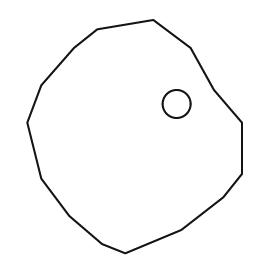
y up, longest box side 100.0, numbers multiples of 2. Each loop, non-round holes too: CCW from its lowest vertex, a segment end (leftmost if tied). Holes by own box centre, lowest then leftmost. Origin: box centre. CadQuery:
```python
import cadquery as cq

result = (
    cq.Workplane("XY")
    .moveTo(-4.0, -50.0)
    .lineTo(20.0, -40.0)
    .lineTo(38.0, -26.0)
    .lineTo(46.0, -16.0)
    .lineTo(46.0, 6.0)
    .lineTo(34.0, 20.0)
    .lineTo(24.0, 38.0)
    .lineTo(8.0, 50.0)
    .lineTo(-16.0, 46.0)
    .lineTo(-26.0, 38.0)
    .lineTo(-40.0, 22.0)
    .lineTo(-46.0, 6.0)
    .lineTo(-40.0, -18.0)
    .lineTo(-28.0, -34.0)
    .lineTo(-14.0, -46.0)
    .close()
    .moveTo(18.0, 14.0)
    .circle(6.0)
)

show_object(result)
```